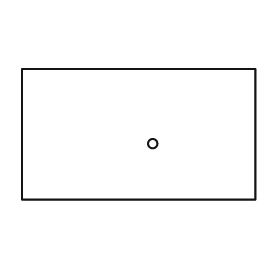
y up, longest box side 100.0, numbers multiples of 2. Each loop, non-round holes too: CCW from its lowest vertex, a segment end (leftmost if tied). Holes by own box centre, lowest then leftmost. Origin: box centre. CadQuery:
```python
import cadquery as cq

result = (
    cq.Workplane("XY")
    .moveTo(-50.0, -28.0)
    .lineTo(50.0, -28.0)
    .lineTo(50.0, 28.0)
    .lineTo(-50.0, 28.0)
    .close()
    .moveTo(6.0, -4.0)
    .circle(2.0)
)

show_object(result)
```